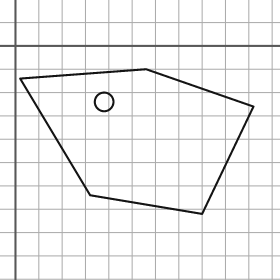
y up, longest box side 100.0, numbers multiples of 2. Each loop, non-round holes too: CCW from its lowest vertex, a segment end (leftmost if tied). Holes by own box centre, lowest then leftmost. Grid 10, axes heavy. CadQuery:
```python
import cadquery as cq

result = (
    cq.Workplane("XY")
    .moveTo(80.0, -72.0)
    .lineTo(102.0, -26.0)
    .lineTo(56.0, -10.0)
    .lineTo(2.0, -14.0)
    .lineTo(32.0, -64.0)
    .close()
    .moveTo(38.0, -24.0)
    .circle(4.0)
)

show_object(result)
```